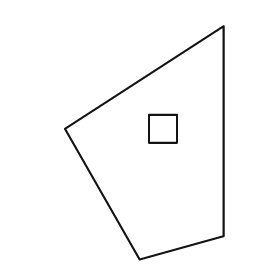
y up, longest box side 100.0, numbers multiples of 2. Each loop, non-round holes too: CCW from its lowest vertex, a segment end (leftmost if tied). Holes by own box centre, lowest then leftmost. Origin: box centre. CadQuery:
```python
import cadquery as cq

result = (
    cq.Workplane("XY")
    .moveTo(-2.0, -50.0)
    .lineTo(34.0, -40.0)
    .lineTo(34.0, 50.0)
    .lineTo(-34.0, 6.0)
    .close()
    .moveTo(2.0, 0.0)
    .lineTo(14.0, 0.0)
    .lineTo(14.0, 12.0)
    .lineTo(2.0, 12.0)
    .close()
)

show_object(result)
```